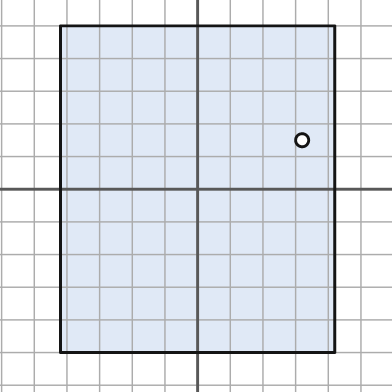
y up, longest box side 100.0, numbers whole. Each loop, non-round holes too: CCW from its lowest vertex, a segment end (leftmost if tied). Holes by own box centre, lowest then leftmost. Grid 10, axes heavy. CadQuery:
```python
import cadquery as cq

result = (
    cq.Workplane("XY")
    .moveTo(-42.0, -50.0)
    .lineTo(42.0, -50.0)
    .lineTo(42.0, 50.0)
    .lineTo(-42.0, 50.0)
    .close()
    .moveTo(32.0, 15.0)
    .circle(2.0)
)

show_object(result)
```